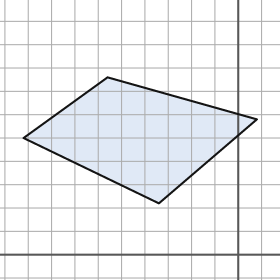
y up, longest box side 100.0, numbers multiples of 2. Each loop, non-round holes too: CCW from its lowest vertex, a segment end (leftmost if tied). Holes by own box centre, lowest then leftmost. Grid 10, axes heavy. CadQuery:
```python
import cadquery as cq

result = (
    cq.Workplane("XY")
    .moveTo(-34.0, 22.0)
    .lineTo(8.0, 58.0)
    .lineTo(-56.0, 76.0)
    .lineTo(-92.0, 50.0)
    .close()
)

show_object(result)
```